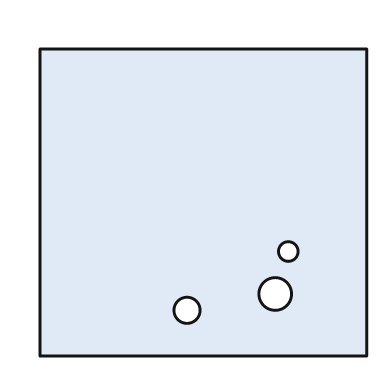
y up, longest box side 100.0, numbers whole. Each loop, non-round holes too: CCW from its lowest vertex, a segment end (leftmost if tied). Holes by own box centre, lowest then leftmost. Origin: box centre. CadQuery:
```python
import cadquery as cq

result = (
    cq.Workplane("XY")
    .moveTo(-50.0, -47.0)
    .lineTo(50.0, -47.0)
    .lineTo(50.0, 47.0)
    .lineTo(-50.0, 47.0)
    .close()
    .moveTo(-5.0, -33.0)
    .circle(4.0)
    .moveTo(22.0, -28.0)
    .circle(5.0)
    .moveTo(26.0, -15.0)
    .circle(3.0)
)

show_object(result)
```